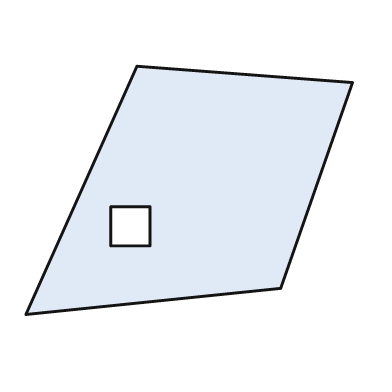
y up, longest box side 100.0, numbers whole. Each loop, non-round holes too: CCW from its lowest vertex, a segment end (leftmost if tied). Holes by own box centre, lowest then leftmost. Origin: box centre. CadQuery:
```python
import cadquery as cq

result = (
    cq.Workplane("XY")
    .moveTo(-50.0, -38.0)
    .lineTo(28.0, -30.0)
    .lineTo(50.0, 33.0)
    .lineTo(-16.0, 38.0)
    .close()
    .moveTo(-24.0, -17.0)
    .lineTo(-12.0, -17.0)
    .lineTo(-12.0, -5.0)
    .lineTo(-24.0, -5.0)
    .close()
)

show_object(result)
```